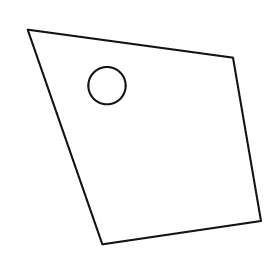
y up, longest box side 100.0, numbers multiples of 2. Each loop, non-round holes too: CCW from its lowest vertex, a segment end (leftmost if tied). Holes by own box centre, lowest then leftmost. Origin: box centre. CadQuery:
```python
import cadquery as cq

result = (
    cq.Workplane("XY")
    .moveTo(-18.0, -46.0)
    .lineTo(50.0, -36.0)
    .lineTo(38.0, 34.0)
    .lineTo(-50.0, 46.0)
    .close()
    .moveTo(-16.0, 22.0)
    .circle(8.0)
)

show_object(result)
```